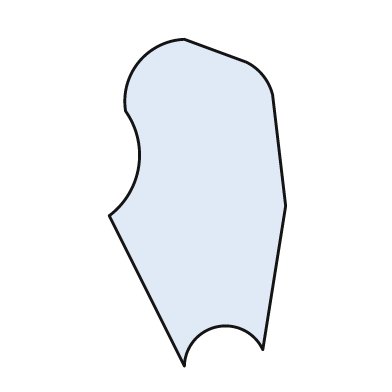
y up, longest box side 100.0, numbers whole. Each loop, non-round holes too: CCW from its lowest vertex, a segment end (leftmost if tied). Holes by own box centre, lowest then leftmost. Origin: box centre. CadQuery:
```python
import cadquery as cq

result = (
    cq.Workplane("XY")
    .moveTo(-4.0, -50.0)
    .threePointArc((6.0, -38.0), (20.0, -45.0))
    .lineTo(27.0, -1.0)
    .lineTo(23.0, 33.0)
    .threePointArc((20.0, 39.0), (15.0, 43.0))
    .lineTo(-4.0, 50.0)
    .threePointArc((-18.0, 43.0), (-22.0, 28.0))
    .threePointArc((-18.0, 11.0), (-27.0, -4.0))
    .close()
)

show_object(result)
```